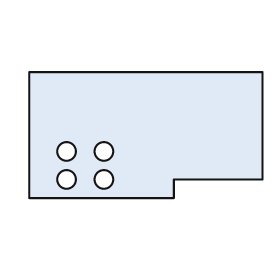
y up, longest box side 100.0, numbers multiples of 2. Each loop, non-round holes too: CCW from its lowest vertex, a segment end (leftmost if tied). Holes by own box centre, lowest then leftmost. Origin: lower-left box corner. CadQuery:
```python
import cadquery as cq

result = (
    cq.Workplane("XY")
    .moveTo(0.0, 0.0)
    .lineTo(62.0, 0.0)
    .lineTo(62.0, 8.0)
    .lineTo(100.0, 8.0)
    .lineTo(100.0, 54.0)
    .lineTo(0.0, 54.0)
    .close()
    .moveTo(16.0, 8.0)
    .circle(4.0)
    .moveTo(32.0, 8.0)
    .circle(4.0)
    .moveTo(16.0, 20.0)
    .circle(4.0)
    .moveTo(32.0, 20.0)
    .circle(4.0)
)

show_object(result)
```